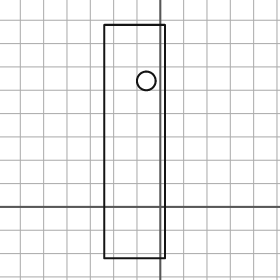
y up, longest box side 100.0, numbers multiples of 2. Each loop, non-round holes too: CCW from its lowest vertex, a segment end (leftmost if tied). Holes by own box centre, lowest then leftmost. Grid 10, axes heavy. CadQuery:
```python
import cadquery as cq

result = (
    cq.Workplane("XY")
    .moveTo(-24.0, -22.0)
    .lineTo(2.0, -22.0)
    .lineTo(2.0, 78.0)
    .lineTo(-24.0, 78.0)
    .close()
    .moveTo(-6.0, 54.0)
    .circle(4.0)
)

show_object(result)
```